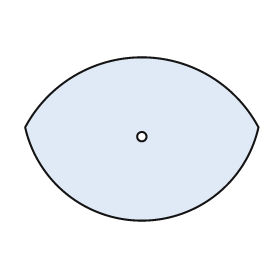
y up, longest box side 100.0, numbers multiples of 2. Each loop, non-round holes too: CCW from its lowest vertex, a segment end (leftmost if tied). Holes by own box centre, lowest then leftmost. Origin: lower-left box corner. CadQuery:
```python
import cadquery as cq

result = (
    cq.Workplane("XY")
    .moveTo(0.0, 40.0)
    .threePointArc((50.0, 0.0), (100.0, 40.0))
    .threePointArc((50.0, 70.0), (0.0, 40.0))
    .close()
    .moveTo(50.0, 36.0)
    .circle(2.0)
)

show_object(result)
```